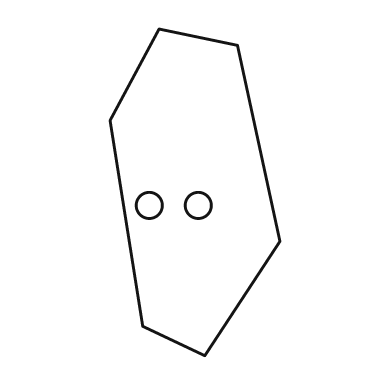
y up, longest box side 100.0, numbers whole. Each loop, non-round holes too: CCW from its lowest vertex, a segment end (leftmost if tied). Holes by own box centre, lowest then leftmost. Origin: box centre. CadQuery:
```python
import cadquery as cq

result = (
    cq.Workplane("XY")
    .moveTo(3.0, -50.0)
    .lineTo(26.0, -15.0)
    .lineTo(13.0, 45.0)
    .lineTo(-11.0, 50.0)
    .lineTo(-26.0, 22.0)
    .lineTo(-16.0, -41.0)
    .close()
    .moveTo(-14.0, -4.0)
    .circle(4.0)
    .moveTo(1.0, -4.0)
    .circle(4.0)
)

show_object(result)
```